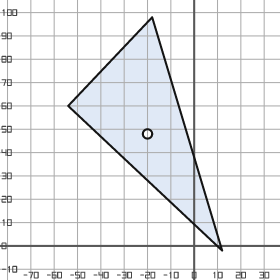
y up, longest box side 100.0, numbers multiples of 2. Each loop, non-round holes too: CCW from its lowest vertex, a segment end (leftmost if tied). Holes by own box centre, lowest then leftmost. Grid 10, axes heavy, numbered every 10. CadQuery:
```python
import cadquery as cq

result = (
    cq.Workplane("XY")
    .moveTo(12.0, -2.0)
    .lineTo(-18.0, 98.0)
    .lineTo(-54.0, 60.0)
    .close()
    .moveTo(-20.0, 48.0)
    .circle(2.0)
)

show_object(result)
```